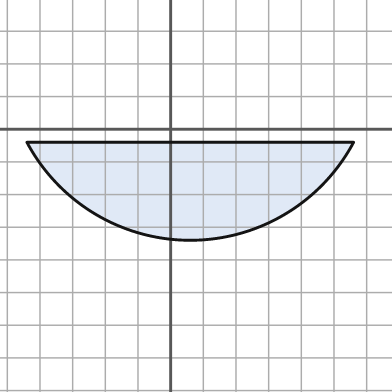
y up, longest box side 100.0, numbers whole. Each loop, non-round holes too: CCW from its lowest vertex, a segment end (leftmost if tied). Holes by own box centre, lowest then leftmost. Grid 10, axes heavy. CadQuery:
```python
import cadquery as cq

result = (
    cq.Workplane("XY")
    .moveTo(-44.0, -4.0)
    .threePointArc((6.0, -34.0), (56.0, -4.0))
    .close()
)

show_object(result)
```